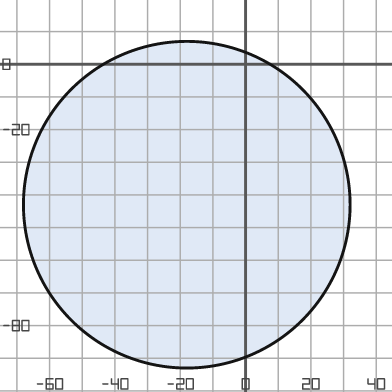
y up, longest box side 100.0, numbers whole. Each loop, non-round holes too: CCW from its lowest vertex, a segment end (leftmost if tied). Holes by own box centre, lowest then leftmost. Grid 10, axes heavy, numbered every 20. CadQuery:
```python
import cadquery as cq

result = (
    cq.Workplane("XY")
    .moveTo(-18.0, -43.0)
    .circle(50.0)
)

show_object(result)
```